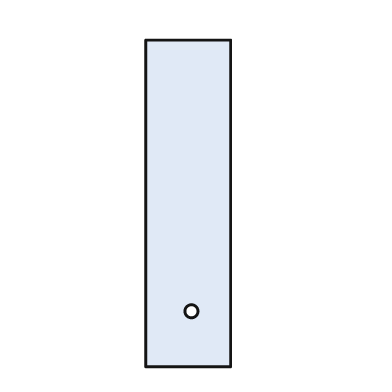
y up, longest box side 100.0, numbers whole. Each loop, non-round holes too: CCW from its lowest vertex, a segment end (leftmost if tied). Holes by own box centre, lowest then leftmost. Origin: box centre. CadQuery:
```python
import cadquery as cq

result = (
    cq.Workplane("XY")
    .moveTo(-13.0, -50.0)
    .lineTo(13.0, -50.0)
    .lineTo(13.0, 50.0)
    .lineTo(-13.0, 50.0)
    .close()
    .moveTo(1.0, -33.0)
    .circle(2.0)
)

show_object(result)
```